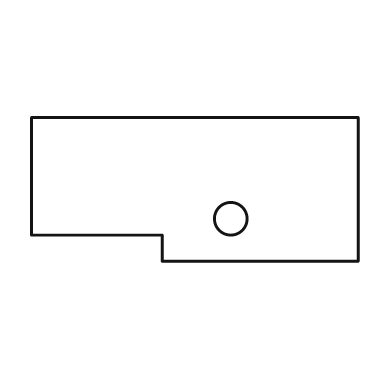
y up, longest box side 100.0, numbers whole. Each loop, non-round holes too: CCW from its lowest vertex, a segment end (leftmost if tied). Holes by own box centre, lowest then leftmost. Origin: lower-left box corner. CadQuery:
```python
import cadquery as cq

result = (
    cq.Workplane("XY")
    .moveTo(40.0, 0.0)
    .lineTo(100.0, 0.0)
    .lineTo(100.0, 44.0)
    .lineTo(0.0, 44.0)
    .lineTo(0.0, 8.0)
    .lineTo(40.0, 8.0)
    .close()
    .moveTo(61.0, 13.0)
    .circle(5.0)
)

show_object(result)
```